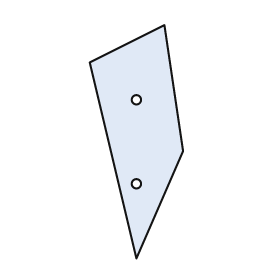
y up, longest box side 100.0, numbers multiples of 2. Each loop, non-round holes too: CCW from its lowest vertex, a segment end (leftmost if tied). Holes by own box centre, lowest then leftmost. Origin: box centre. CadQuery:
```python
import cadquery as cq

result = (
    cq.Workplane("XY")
    .moveTo(0.0, -50.0)
    .lineTo(20.0, -4.0)
    .lineTo(12.0, 50.0)
    .lineTo(-20.0, 34.0)
    .close()
    .moveTo(0.0, -18.0)
    .circle(2.0)
    .moveTo(0.0, 18.0)
    .circle(2.0)
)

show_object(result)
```